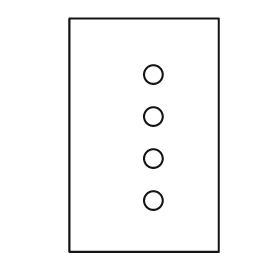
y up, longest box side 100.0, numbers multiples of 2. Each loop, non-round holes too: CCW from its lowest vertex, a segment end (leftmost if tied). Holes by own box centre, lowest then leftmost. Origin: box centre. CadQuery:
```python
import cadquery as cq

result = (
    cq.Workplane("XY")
    .moveTo(-32.0, -50.0)
    .lineTo(32.0, -50.0)
    .lineTo(32.0, 50.0)
    .lineTo(-32.0, 50.0)
    .close()
    .moveTo(4.0, -28.0)
    .circle(4.0)
    .moveTo(4.0, -10.0)
    .circle(4.0)
    .moveTo(4.0, 8.0)
    .circle(4.0)
    .moveTo(4.0, 26.0)
    .circle(4.0)
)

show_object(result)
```